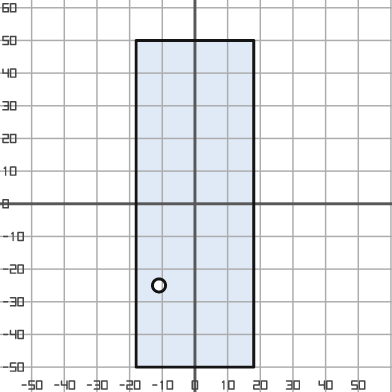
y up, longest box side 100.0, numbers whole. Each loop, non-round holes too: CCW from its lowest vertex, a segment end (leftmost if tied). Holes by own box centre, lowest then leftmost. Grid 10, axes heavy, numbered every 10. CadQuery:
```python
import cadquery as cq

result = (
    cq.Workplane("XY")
    .moveTo(-18.0, -50.0)
    .lineTo(18.0, -50.0)
    .lineTo(18.0, 50.0)
    .lineTo(-18.0, 50.0)
    .close()
    .moveTo(-11.0, -25.0)
    .circle(2.0)
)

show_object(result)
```